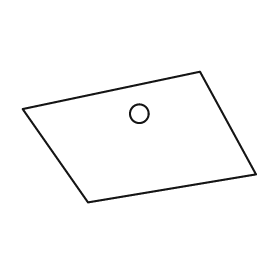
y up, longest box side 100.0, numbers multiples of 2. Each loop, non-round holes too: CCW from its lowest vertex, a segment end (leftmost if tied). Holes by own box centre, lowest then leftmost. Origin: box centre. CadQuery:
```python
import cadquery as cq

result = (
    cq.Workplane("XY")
    .moveTo(-22.0, -28.0)
    .lineTo(50.0, -16.0)
    .lineTo(26.0, 28.0)
    .lineTo(-50.0, 12.0)
    .close()
    .moveTo(0.0, 10.0)
    .circle(4.0)
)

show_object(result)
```